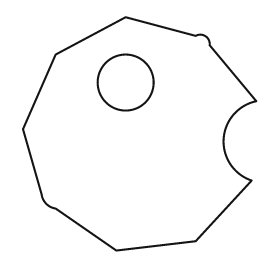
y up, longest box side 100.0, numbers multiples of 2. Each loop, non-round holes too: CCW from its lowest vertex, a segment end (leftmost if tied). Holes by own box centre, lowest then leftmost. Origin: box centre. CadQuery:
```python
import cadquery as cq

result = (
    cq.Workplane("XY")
    .moveTo(-10.0, -50.0)
    .lineTo(24.0, -46.0)
    .lineTo(48.0, -20.0)
    .threePointArc((36.0, -2.0), (50.0, 14.0))
    .lineTo(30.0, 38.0)
    .threePointArc((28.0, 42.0), (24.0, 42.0))
    .lineTo(-6.0, 50.0)
    .lineTo(-36.0, 34.0)
    .lineTo(-50.0, 2.0)
    .lineTo(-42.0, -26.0)
    .threePointArc((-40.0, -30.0), (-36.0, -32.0))
    .close()
    .moveTo(-6.0, 22.0)
    .circle(12.0)
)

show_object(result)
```